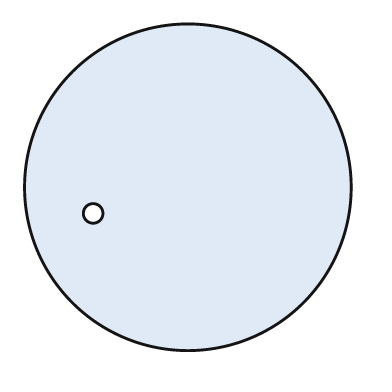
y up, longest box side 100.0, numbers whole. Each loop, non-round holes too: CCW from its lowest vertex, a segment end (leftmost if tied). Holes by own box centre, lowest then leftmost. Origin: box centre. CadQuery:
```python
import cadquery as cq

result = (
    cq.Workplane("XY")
    .moveTo(0.0, 0.0)
    .circle(50.0)
    .moveTo(-29.0, -8.0)
    .circle(3.0)
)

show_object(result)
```